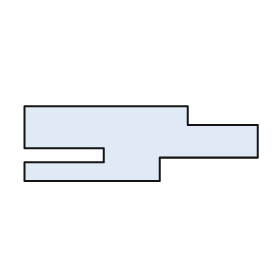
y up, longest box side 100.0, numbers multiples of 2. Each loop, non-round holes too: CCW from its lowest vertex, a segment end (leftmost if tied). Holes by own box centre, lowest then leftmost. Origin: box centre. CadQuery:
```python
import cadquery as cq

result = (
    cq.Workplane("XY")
    .moveTo(-50.0, -16.0)
    .lineTo(8.0, -16.0)
    .lineTo(8.0, -6.0)
    .lineTo(50.0, -6.0)
    .lineTo(50.0, 8.0)
    .lineTo(20.0, 8.0)
    .lineTo(20.0, 16.0)
    .lineTo(-50.0, 16.0)
    .lineTo(-50.0, -2.0)
    .lineTo(-16.0, -2.0)
    .lineTo(-16.0, -8.0)
    .lineTo(-50.0, -8.0)
    .close()
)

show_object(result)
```